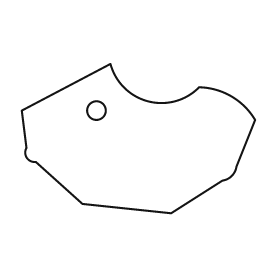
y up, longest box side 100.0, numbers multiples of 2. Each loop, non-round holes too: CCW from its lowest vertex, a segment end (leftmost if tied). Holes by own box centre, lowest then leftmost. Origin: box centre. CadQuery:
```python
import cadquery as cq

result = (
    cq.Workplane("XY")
    .moveTo(14.0, -32.0)
    .lineTo(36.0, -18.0)
    .threePointArc((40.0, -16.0), (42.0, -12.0))
    .lineTo(50.0, 8.0)
    .threePointArc((40.0, 18.0), (26.0, 22.0))
    .threePointArc((4.0, 16.0), (-12.0, 32.0))
    .lineTo(-50.0, 12.0)
    .lineTo(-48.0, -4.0)
    .threePointArc((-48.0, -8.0), (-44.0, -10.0))
    .lineTo(-24.0, -28.0)
    .close()
    .moveTo(-18.0, 12.0)
    .circle(4.0)
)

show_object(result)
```